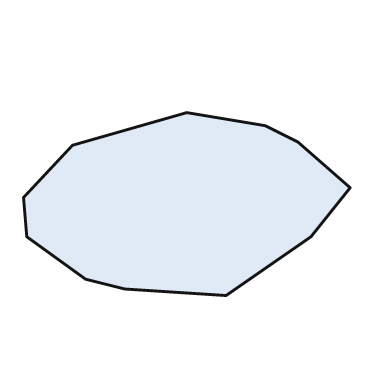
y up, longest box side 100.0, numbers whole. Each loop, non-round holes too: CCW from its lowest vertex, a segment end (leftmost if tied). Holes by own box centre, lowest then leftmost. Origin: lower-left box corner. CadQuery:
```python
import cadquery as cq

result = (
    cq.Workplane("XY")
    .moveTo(62.0, 0.0)
    .lineTo(88.0, 18.0)
    .lineTo(100.0, 33.0)
    .lineTo(84.0, 47.0)
    .lineTo(74.0, 52.0)
    .lineTo(50.0, 56.0)
    .lineTo(15.0, 46.0)
    .lineTo(0.0, 30.0)
    .lineTo(1.0, 18.0)
    .lineTo(19.0, 5.0)
    .lineTo(31.0, 2.0)
    .close()
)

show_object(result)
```